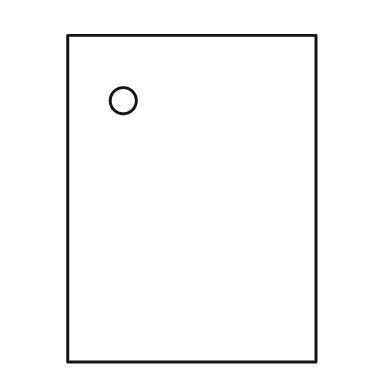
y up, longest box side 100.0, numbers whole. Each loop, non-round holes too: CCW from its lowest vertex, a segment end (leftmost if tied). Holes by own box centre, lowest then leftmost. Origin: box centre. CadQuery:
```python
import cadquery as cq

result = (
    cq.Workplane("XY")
    .moveTo(-38.0, -50.0)
    .lineTo(38.0, -50.0)
    .lineTo(38.0, 50.0)
    .lineTo(-38.0, 50.0)
    .close()
    .moveTo(-21.0, 30.0)
    .circle(4.0)
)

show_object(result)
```